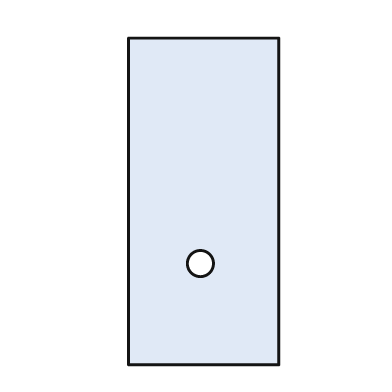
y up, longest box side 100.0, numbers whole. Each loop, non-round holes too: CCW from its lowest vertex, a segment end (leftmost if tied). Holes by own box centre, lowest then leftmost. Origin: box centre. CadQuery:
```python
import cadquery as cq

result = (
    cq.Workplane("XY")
    .moveTo(-23.0, -50.0)
    .lineTo(23.0, -50.0)
    .lineTo(23.0, 50.0)
    .lineTo(-23.0, 50.0)
    .close()
    .moveTo(-1.0, -19.0)
    .circle(4.0)
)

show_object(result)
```